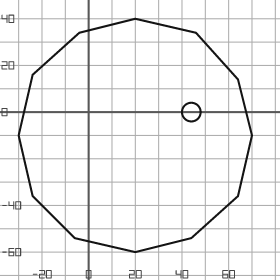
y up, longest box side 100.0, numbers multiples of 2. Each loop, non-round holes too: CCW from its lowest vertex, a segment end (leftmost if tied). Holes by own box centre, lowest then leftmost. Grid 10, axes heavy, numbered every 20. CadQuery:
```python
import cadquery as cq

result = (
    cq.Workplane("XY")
    .moveTo(20.0, -60.0)
    .lineTo(44.0, -54.0)
    .lineTo(64.0, -36.0)
    .lineTo(70.0, -10.0)
    .lineTo(64.0, 14.0)
    .lineTo(46.0, 34.0)
    .lineTo(20.0, 40.0)
    .lineTo(-4.0, 34.0)
    .lineTo(-24.0, 16.0)
    .lineTo(-30.0, -10.0)
    .lineTo(-24.0, -36.0)
    .lineTo(-6.0, -54.0)
    .close()
    .moveTo(44.0, 0.0)
    .circle(4.0)
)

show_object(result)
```